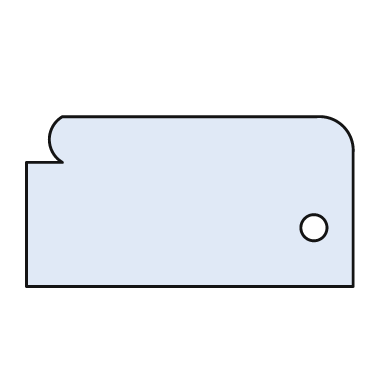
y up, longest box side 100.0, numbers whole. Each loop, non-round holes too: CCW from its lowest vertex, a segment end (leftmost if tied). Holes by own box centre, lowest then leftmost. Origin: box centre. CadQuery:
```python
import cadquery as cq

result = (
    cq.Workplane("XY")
    .moveTo(-50.0, -26.0)
    .lineTo(50.0, -26.0)
    .lineTo(50.0, 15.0)
    .threePointArc((47.0, 23.0), (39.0, 26.0))
    .lineTo(-39.0, 26.0)
    .threePointArc((-43.0, 19.0), (-39.0, 12.0))
    .lineTo(-50.0, 12.0)
    .close()
    .moveTo(38.0, -8.0)
    .circle(4.0)
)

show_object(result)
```